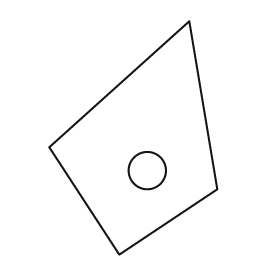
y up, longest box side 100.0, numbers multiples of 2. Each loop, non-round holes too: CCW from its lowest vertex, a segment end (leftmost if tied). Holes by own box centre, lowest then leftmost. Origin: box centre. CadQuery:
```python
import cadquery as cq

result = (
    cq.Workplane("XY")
    .moveTo(-6.0, -50.0)
    .lineTo(36.0, -22.0)
    .lineTo(24.0, 50.0)
    .lineTo(-36.0, -4.0)
    .close()
    .moveTo(6.0, -14.0)
    .circle(8.0)
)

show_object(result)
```